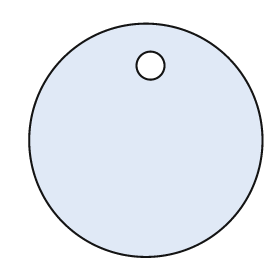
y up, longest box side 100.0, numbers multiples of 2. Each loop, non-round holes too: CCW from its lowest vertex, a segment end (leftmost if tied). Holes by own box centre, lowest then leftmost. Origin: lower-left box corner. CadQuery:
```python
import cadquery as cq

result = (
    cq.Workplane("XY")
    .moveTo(50.0, 50.0)
    .circle(50.0)
    .moveTo(52.0, 82.0)
    .circle(6.0)
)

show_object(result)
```